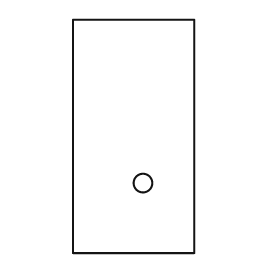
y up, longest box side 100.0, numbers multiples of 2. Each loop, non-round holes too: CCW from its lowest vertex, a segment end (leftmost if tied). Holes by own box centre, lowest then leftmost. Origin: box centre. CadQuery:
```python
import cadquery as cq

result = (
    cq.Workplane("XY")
    .moveTo(-26.0, -50.0)
    .lineTo(26.0, -50.0)
    .lineTo(26.0, 50.0)
    .lineTo(-26.0, 50.0)
    .close()
    .moveTo(4.0, -20.0)
    .circle(4.0)
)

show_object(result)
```